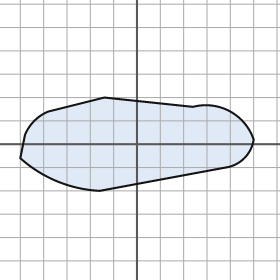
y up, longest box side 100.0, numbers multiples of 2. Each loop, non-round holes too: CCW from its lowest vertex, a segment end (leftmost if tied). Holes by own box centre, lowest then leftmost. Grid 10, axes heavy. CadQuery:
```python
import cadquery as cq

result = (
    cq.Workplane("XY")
    .moveTo(-16.0, -20.0)
    .lineTo(38.0, -10.0)
    .threePointArc((46.0, -6.0), (50.0, 2.0))
    .threePointArc((40.0, 14.0), (24.0, 16.0))
    .lineTo(-14.0, 20.0)
    .lineTo(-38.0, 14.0)
    .threePointArc((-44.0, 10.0), (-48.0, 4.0))
    .lineTo(-50.0, -6.0)
    .threePointArc((-34.0, -16.0), (-16.0, -20.0))
    .close()
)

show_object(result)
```